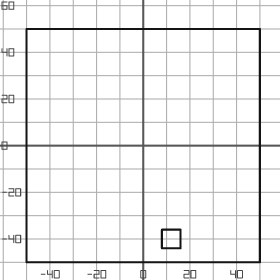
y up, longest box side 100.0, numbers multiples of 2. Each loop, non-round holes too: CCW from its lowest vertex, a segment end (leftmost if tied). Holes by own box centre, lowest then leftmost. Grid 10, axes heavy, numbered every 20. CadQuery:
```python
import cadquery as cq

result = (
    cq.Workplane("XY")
    .moveTo(-50.0, -50.0)
    .lineTo(50.0, -50.0)
    .lineTo(50.0, 50.0)
    .lineTo(-50.0, 50.0)
    .close()
    .moveTo(8.0, -44.0)
    .lineTo(16.0, -44.0)
    .lineTo(16.0, -36.0)
    .lineTo(8.0, -36.0)
    .close()
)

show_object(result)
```